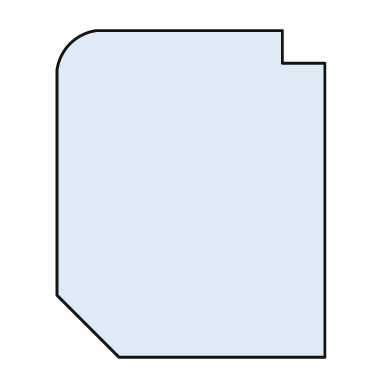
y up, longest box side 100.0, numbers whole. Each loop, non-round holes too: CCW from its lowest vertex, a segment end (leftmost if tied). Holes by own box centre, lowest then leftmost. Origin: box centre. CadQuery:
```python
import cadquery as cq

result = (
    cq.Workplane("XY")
    .moveTo(-22.0, -50.0)
    .lineTo(41.0, -50.0)
    .lineTo(41.0, 40.0)
    .lineTo(28.0, 40.0)
    .lineTo(28.0, 50.0)
    .lineTo(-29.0, 50.0)
    .threePointArc((-37.0, 46.0), (-41.0, 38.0))
    .lineTo(-41.0, -31.0)
    .close()
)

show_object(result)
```